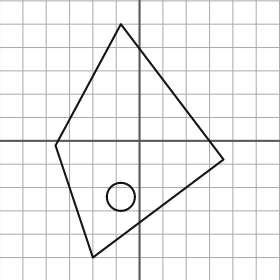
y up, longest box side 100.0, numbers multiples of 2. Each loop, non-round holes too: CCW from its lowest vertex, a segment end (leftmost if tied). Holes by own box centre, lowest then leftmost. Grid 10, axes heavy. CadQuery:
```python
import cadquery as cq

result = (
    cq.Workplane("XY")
    .moveTo(-20.0, -50.0)
    .lineTo(36.0, -8.0)
    .lineTo(-8.0, 50.0)
    .lineTo(-36.0, -2.0)
    .close()
    .moveTo(-8.0, -24.0)
    .circle(6.0)
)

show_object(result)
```